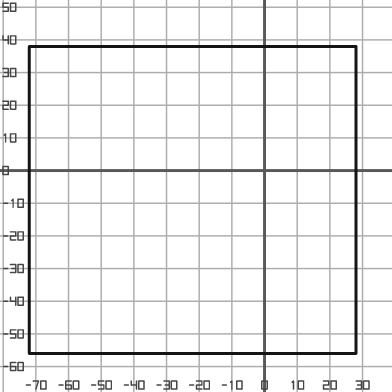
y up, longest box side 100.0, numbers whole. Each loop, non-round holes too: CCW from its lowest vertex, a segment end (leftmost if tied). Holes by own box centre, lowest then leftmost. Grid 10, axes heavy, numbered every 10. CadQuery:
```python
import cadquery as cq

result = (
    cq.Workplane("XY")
    .moveTo(-72.0, -56.0)
    .lineTo(28.0, -56.0)
    .lineTo(28.0, 38.0)
    .lineTo(-72.0, 38.0)
    .close()
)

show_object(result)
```